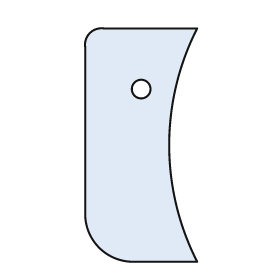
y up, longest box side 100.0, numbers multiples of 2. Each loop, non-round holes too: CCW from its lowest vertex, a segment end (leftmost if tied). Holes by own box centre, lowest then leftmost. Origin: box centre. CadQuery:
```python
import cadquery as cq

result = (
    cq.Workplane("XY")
    .moveTo(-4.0, -50.0)
    .lineTo(24.0, -50.0)
    .threePointArc((12.0, 0.0), (24.0, 50.0))
    .lineTo(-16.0, 50.0)
    .threePointArc((-22.0, 48.0), (-24.0, 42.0))
    .lineTo(-24.0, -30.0)
    .threePointArc((-18.0, -44.0), (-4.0, -50.0))
    .close()
    .moveTo(0.0, 24.0)
    .circle(4.0)
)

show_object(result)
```